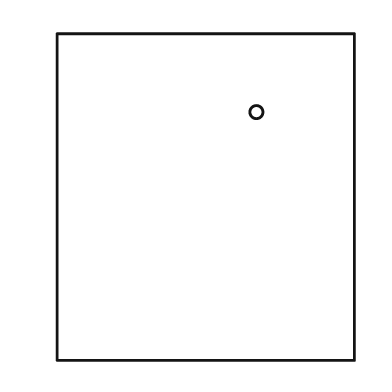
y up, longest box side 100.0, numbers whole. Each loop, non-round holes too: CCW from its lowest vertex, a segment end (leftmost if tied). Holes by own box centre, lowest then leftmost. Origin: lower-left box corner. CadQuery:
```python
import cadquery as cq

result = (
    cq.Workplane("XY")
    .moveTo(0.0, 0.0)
    .lineTo(91.0, 0.0)
    .lineTo(91.0, 100.0)
    .lineTo(0.0, 100.0)
    .close()
    .moveTo(61.0, 76.0)
    .circle(2.0)
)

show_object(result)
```